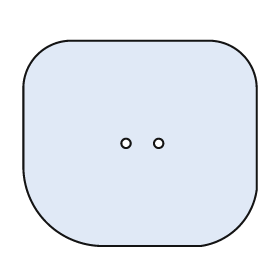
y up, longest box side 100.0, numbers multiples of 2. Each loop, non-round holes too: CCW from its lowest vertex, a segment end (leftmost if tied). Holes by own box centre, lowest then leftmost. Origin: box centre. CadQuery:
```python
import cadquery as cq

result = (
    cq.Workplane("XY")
    .moveTo(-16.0, -44.0)
    .lineTo(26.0, -44.0)
    .threePointArc((42.0, -36.0), (50.0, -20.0))
    .lineTo(50.0, 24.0)
    .threePointArc((44.0, 38.0), (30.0, 44.0))
    .lineTo(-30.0, 44.0)
    .threePointArc((-44.0, 38.0), (-50.0, 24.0))
    .lineTo(-50.0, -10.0)
    .threePointArc((-40.0, -34.0), (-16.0, -44.0))
    .close()
    .moveTo(-6.0, 0.0)
    .circle(2.0)
    .moveTo(8.0, 0.0)
    .circle(2.0)
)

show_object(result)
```